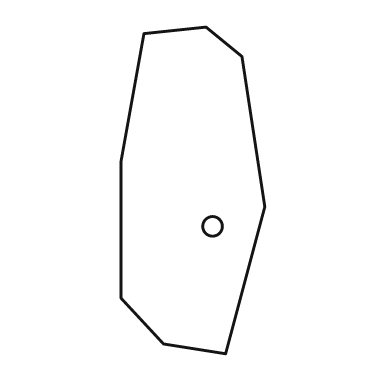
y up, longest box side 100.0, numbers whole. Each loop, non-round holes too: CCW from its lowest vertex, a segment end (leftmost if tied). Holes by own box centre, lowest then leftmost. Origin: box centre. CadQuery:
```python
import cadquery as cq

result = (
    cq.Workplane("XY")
    .moveTo(10.0, -50.0)
    .lineTo(22.0, -5.0)
    .lineTo(15.0, 41.0)
    .lineTo(4.0, 50.0)
    .lineTo(-15.0, 48.0)
    .lineTo(-22.0, 9.0)
    .lineTo(-22.0, -33.0)
    .lineTo(-9.0, -47.0)
    .close()
    .moveTo(6.0, -11.0)
    .circle(3.0)
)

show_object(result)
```